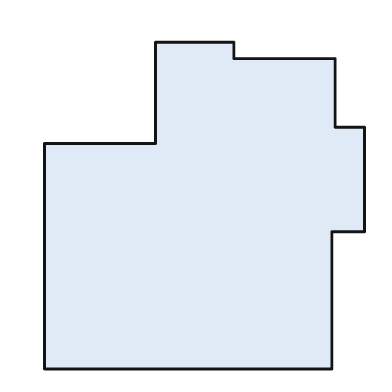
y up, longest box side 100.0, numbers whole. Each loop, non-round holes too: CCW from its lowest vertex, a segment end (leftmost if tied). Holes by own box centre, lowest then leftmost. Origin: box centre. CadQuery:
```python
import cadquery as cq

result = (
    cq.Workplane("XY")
    .moveTo(-49.0, -50.0)
    .lineTo(39.0, -50.0)
    .lineTo(39.0, -8.0)
    .lineTo(49.0, -8.0)
    .lineTo(49.0, 24.0)
    .lineTo(40.0, 24.0)
    .lineTo(40.0, 45.0)
    .lineTo(9.0, 45.0)
    .lineTo(9.0, 50.0)
    .lineTo(-15.0, 50.0)
    .lineTo(-15.0, 19.0)
    .lineTo(-49.0, 19.0)
    .close()
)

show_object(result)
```